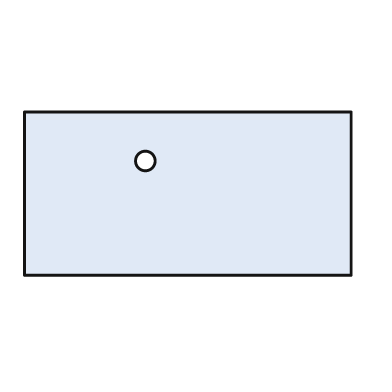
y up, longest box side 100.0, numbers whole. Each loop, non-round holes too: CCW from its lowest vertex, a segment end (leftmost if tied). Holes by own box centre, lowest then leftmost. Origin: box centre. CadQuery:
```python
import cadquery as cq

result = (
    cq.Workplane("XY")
    .moveTo(-50.0, -25.0)
    .lineTo(50.0, -25.0)
    .lineTo(50.0, 25.0)
    .lineTo(-50.0, 25.0)
    .close()
    .moveTo(-13.0, 10.0)
    .circle(3.0)
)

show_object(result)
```